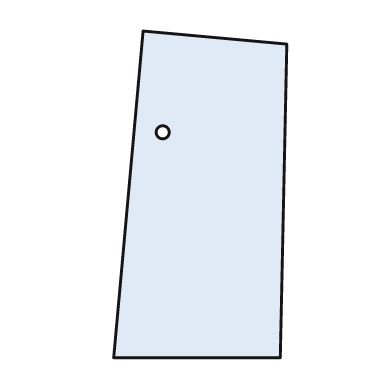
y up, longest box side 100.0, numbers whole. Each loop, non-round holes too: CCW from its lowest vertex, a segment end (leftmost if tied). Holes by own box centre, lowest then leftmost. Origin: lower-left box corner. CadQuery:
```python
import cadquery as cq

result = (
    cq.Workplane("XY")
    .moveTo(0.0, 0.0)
    .lineTo(51.0, 0.0)
    .lineTo(53.0, 96.0)
    .lineTo(9.0, 100.0)
    .close()
    .moveTo(15.0, 69.0)
    .circle(2.0)
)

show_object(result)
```